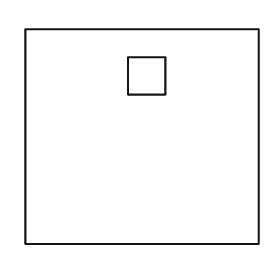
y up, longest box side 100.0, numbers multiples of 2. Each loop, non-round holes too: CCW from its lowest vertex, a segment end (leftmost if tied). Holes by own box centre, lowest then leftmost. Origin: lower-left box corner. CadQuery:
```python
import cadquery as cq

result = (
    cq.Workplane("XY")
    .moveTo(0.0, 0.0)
    .lineTo(100.0, 0.0)
    .lineTo(100.0, 92.0)
    .lineTo(0.0, 92.0)
    .close()
    .moveTo(44.0, 64.0)
    .lineTo(60.0, 64.0)
    .lineTo(60.0, 80.0)
    .lineTo(44.0, 80.0)
    .close()
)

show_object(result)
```